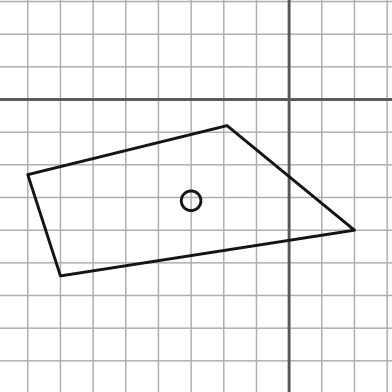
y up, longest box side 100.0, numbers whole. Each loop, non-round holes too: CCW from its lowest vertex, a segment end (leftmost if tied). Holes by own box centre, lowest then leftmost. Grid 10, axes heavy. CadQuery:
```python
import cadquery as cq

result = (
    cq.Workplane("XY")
    .moveTo(-70.0, -54.0)
    .lineTo(20.0, -40.0)
    .lineTo(-19.0, -8.0)
    .lineTo(-80.0, -23.0)
    .close()
    .moveTo(-30.0, -31.0)
    .circle(3.0)
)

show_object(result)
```